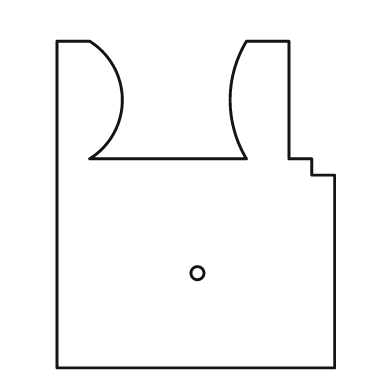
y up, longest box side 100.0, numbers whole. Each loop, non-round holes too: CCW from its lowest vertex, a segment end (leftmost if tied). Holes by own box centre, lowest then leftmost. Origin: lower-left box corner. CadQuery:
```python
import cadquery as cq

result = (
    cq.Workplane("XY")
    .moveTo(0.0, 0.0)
    .lineTo(85.0, 0.0)
    .lineTo(85.0, 59.0)
    .lineTo(78.0, 59.0)
    .lineTo(78.0, 64.0)
    .lineTo(71.0, 64.0)
    .lineTo(71.0, 100.0)
    .lineTo(58.0, 100.0)
    .threePointArc((53.0, 82.0), (58.0, 64.0))
    .lineTo(10.0, 64.0)
    .threePointArc((20.0, 82.0), (10.0, 100.0))
    .lineTo(0.0, 100.0)
    .close()
    .moveTo(43.0, 29.0)
    .circle(2.0)
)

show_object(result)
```